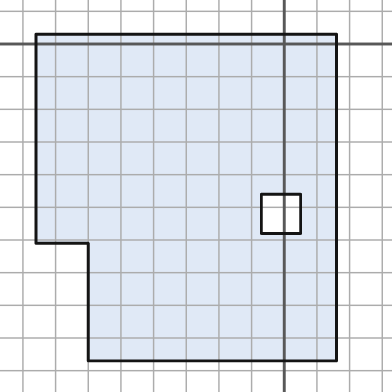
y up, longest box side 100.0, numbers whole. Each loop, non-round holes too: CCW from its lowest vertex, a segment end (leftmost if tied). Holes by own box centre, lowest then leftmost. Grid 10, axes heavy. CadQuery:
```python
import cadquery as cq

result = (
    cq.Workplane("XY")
    .moveTo(-60.0, -97.0)
    .lineTo(16.0, -97.0)
    .lineTo(16.0, 3.0)
    .lineTo(-76.0, 3.0)
    .lineTo(-76.0, -61.0)
    .lineTo(-60.0, -61.0)
    .close()
    .moveTo(-7.0, -58.0)
    .lineTo(5.0, -58.0)
    .lineTo(5.0, -46.0)
    .lineTo(-7.0, -46.0)
    .close()
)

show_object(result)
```